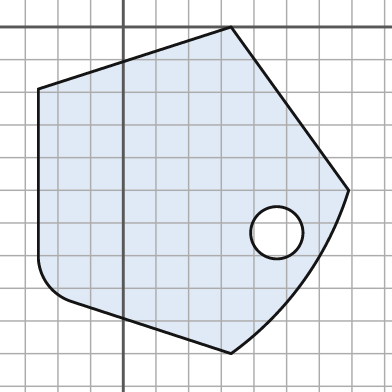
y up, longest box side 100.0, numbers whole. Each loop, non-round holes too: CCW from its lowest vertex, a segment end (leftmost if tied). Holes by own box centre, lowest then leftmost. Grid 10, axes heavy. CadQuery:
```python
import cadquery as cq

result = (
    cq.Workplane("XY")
    .moveTo(33.0, -100.0)
    .threePointArc((55.0, -78.0), (69.0, -50.0))
    .lineTo(33.0, 0.0)
    .lineTo(-26.0, -19.0)
    .lineTo(-26.0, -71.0)
    .threePointArc((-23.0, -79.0), (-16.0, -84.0))
    .close()
    .moveTo(47.0, -63.0)
    .circle(8.0)
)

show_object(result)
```